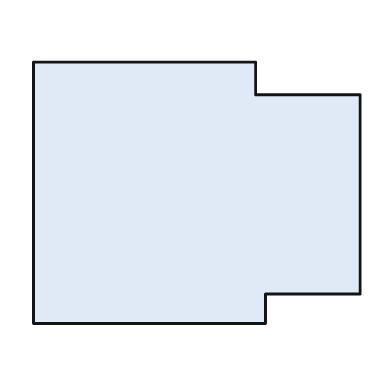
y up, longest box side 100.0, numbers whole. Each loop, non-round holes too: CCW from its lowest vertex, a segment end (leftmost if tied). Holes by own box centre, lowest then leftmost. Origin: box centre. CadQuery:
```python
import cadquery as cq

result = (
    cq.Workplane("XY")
    .moveTo(-50.0, -40.0)
    .lineTo(21.0, -40.0)
    .lineTo(21.0, -31.0)
    .lineTo(50.0, -31.0)
    .lineTo(50.0, 30.0)
    .lineTo(18.0, 30.0)
    .lineTo(18.0, 40.0)
    .lineTo(-50.0, 40.0)
    .close()
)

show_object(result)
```